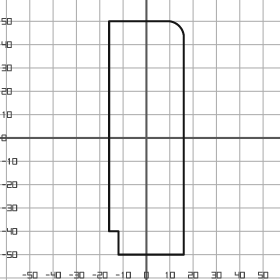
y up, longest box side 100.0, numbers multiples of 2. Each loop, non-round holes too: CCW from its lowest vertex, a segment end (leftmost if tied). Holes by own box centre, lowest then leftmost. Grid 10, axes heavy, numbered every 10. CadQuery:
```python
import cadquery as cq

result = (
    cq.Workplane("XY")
    .moveTo(-12.0, -50.0)
    .lineTo(16.0, -50.0)
    .lineTo(16.0, 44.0)
    .threePointArc((14.0, 48.0), (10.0, 50.0))
    .lineTo(-16.0, 50.0)
    .lineTo(-16.0, -40.0)
    .lineTo(-12.0, -40.0)
    .close()
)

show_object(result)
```